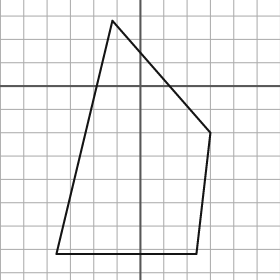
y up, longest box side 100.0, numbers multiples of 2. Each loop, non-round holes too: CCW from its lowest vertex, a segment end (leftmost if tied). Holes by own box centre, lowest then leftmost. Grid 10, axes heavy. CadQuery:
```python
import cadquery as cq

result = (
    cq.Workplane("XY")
    .moveTo(-36.0, -72.0)
    .lineTo(24.0, -72.0)
    .lineTo(30.0, -20.0)
    .lineTo(-12.0, 28.0)
    .close()
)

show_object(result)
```